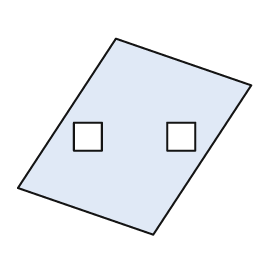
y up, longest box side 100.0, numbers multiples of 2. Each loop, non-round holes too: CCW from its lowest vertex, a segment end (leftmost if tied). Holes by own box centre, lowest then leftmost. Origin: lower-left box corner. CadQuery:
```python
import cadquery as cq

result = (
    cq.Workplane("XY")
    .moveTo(58.0, 0.0)
    .lineTo(100.0, 64.0)
    .lineTo(42.0, 84.0)
    .lineTo(0.0, 20.0)
    .close()
    .moveTo(24.0, 36.0)
    .lineTo(36.0, 36.0)
    .lineTo(36.0, 48.0)
    .lineTo(24.0, 48.0)
    .close()
    .moveTo(64.0, 36.0)
    .lineTo(76.0, 36.0)
    .lineTo(76.0, 48.0)
    .lineTo(64.0, 48.0)
    .close()
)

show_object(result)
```